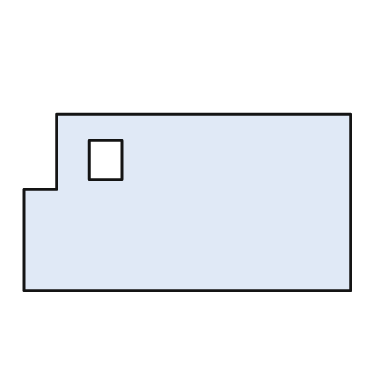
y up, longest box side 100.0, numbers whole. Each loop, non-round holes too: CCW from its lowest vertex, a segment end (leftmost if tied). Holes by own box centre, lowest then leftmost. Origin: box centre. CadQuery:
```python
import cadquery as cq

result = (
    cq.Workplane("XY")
    .moveTo(-50.0, -27.0)
    .lineTo(50.0, -27.0)
    .lineTo(50.0, 27.0)
    .lineTo(-40.0, 27.0)
    .lineTo(-40.0, 4.0)
    .lineTo(-50.0, 4.0)
    .close()
    .moveTo(-30.0, 7.0)
    .lineTo(-20.0, 7.0)
    .lineTo(-20.0, 19.0)
    .lineTo(-30.0, 19.0)
    .close()
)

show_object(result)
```